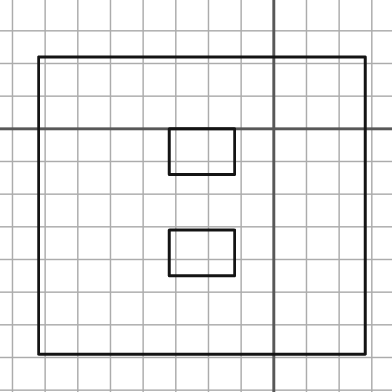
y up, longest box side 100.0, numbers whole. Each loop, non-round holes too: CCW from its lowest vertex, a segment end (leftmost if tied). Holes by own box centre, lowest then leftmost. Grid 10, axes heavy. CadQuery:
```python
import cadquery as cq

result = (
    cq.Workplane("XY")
    .moveTo(-72.0, -69.0)
    .lineTo(28.0, -69.0)
    .lineTo(28.0, 22.0)
    .lineTo(-72.0, 22.0)
    .close()
    .moveTo(-32.0, -45.0)
    .lineTo(-12.0, -45.0)
    .lineTo(-12.0, -31.0)
    .lineTo(-32.0, -31.0)
    .close()
    .moveTo(-32.0, -14.0)
    .lineTo(-12.0, -14.0)
    .lineTo(-12.0, 0.0)
    .lineTo(-32.0, 0.0)
    .close()
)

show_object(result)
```